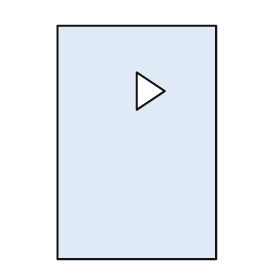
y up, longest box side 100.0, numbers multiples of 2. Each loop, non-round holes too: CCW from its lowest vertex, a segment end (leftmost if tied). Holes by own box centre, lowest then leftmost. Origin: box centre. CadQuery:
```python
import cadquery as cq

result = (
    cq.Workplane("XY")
    .moveTo(-34.0, -50.0)
    .lineTo(34.0, -50.0)
    .lineTo(34.0, 50.0)
    .lineTo(-34.0, 50.0)
    .close()
    .moveTo(0.0, 14.0)
    .lineTo(12.0, 22.0)
    .lineTo(0.0, 30.0)
    .close()
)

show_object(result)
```